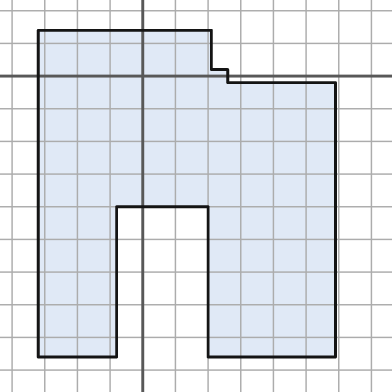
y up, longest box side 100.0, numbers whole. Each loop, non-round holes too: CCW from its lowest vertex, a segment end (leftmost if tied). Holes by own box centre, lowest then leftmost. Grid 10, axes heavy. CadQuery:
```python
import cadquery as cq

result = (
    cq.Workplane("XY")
    .moveTo(-32.0, -86.0)
    .lineTo(-8.0, -86.0)
    .lineTo(-8.0, -40.0)
    .lineTo(20.0, -40.0)
    .lineTo(20.0, -86.0)
    .lineTo(59.0, -86.0)
    .lineTo(59.0, -2.0)
    .lineTo(26.0, -2.0)
    .lineTo(26.0, 2.0)
    .lineTo(21.0, 2.0)
    .lineTo(21.0, 14.0)
    .lineTo(-32.0, 14.0)
    .close()
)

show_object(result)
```